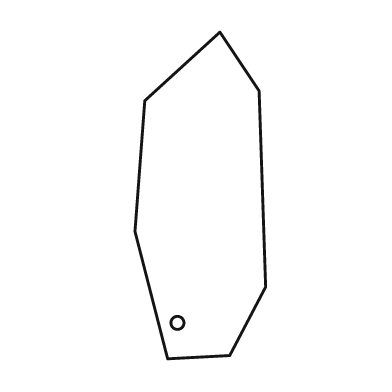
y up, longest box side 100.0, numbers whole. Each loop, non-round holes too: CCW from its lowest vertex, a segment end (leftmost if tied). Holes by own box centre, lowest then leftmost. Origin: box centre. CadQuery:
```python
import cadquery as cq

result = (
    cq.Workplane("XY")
    .moveTo(-10.0, -50.0)
    .lineTo(9.0, -49.0)
    .lineTo(20.0, -28.0)
    .lineTo(18.0, 32.0)
    .lineTo(6.0, 50.0)
    .lineTo(-17.0, 29.0)
    .lineTo(-20.0, -11.0)
    .close()
    .moveTo(-7.0, -39.0)
    .circle(2.0)
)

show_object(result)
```